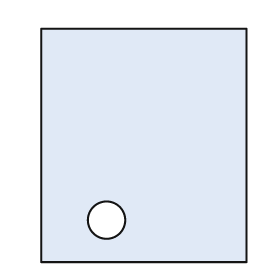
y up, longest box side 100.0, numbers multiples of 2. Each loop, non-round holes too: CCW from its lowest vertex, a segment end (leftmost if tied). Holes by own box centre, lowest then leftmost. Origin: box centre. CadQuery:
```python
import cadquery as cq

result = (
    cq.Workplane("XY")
    .moveTo(-44.0, -50.0)
    .lineTo(44.0, -50.0)
    .lineTo(44.0, 50.0)
    .lineTo(-44.0, 50.0)
    .close()
    .moveTo(-16.0, -32.0)
    .circle(8.0)
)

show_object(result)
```